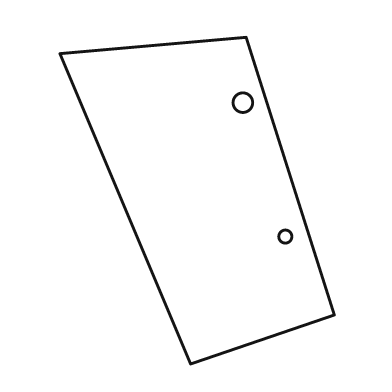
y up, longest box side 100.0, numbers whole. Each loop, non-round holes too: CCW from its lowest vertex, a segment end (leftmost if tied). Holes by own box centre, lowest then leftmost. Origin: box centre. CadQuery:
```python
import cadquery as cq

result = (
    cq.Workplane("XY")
    .moveTo(-2.0, -50.0)
    .lineTo(42.0, -35.0)
    .lineTo(15.0, 50.0)
    .lineTo(-42.0, 45.0)
    .close()
    .moveTo(27.0, -11.0)
    .circle(2.0)
    .moveTo(14.0, 30.0)
    .circle(3.0)
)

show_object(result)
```